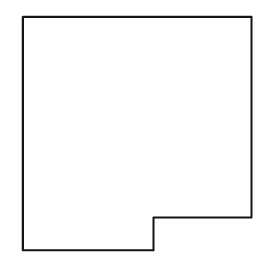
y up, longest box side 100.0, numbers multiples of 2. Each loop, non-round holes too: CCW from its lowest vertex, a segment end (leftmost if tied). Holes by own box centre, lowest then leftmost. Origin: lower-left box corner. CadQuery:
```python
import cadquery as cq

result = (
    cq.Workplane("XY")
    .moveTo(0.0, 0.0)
    .lineTo(56.0, 0.0)
    .lineTo(56.0, 14.0)
    .lineTo(98.0, 14.0)
    .lineTo(98.0, 100.0)
    .lineTo(0.0, 100.0)
    .close()
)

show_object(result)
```